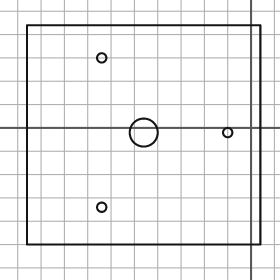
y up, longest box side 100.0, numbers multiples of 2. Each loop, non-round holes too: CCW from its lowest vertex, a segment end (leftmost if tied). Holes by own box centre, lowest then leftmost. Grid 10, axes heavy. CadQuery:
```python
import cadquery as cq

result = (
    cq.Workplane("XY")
    .moveTo(-96.0, -50.0)
    .lineTo(4.0, -50.0)
    .lineTo(4.0, 44.0)
    .lineTo(-96.0, 44.0)
    .close()
    .moveTo(-64.0, -34.0)
    .circle(2.0)
    .moveTo(-46.0, -2.0)
    .circle(6.0)
    .moveTo(-10.0, -2.0)
    .circle(2.0)
    .moveTo(-64.0, 30.0)
    .circle(2.0)
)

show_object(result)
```